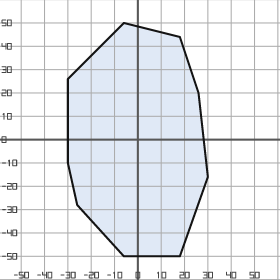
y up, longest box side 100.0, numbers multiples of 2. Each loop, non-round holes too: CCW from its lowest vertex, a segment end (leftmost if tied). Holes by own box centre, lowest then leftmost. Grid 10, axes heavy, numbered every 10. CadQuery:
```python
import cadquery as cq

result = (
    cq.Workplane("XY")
    .moveTo(-6.0, -50.0)
    .lineTo(18.0, -50.0)
    .lineTo(30.0, -16.0)
    .lineTo(26.0, 20.0)
    .lineTo(18.0, 44.0)
    .lineTo(-6.0, 50.0)
    .lineTo(-30.0, 26.0)
    .lineTo(-30.0, -10.0)
    .lineTo(-26.0, -28.0)
    .close()
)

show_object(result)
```